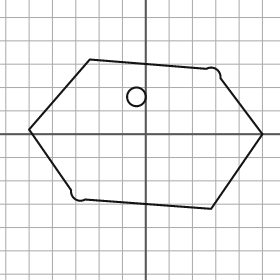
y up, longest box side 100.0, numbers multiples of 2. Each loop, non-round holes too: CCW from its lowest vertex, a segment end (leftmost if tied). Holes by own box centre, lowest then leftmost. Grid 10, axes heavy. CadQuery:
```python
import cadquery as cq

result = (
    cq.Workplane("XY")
    .moveTo(28.0, -32.0)
    .lineTo(50.0, 0.0)
    .lineTo(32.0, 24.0)
    .threePointArc((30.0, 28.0), (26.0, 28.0))
    .lineTo(-24.0, 32.0)
    .lineTo(-50.0, 2.0)
    .lineTo(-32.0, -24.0)
    .threePointArc((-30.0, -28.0), (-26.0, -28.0))
    .close()
    .moveTo(-4.0, 16.0)
    .circle(4.0)
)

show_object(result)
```